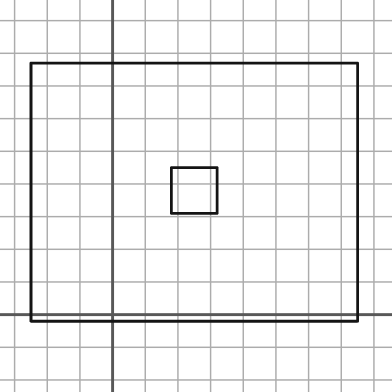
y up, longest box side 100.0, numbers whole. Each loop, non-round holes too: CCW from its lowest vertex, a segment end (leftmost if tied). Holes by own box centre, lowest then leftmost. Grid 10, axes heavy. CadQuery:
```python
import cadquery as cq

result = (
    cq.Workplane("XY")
    .moveTo(-25.0, -2.0)
    .lineTo(75.0, -2.0)
    .lineTo(75.0, 77.0)
    .lineTo(-25.0, 77.0)
    .close()
    .moveTo(18.0, 31.0)
    .lineTo(32.0, 31.0)
    .lineTo(32.0, 45.0)
    .lineTo(18.0, 45.0)
    .close()
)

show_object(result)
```